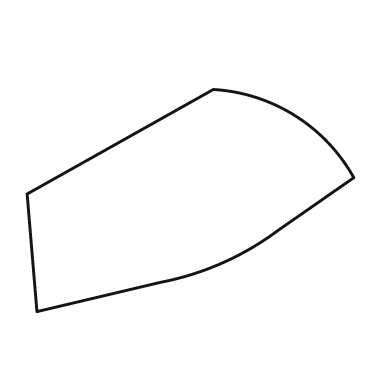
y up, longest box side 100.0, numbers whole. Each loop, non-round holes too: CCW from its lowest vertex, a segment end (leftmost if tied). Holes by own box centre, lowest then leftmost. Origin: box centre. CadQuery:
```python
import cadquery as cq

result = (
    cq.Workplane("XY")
    .moveTo(-47.0, -34.0)
    .lineTo(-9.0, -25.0)
    .threePointArc((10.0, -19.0), (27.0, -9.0))
    .lineTo(50.0, 7.0)
    .threePointArc((32.0, 26.0), (7.0, 34.0))
    .lineTo(-50.0, 2.0)
    .close()
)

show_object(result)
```